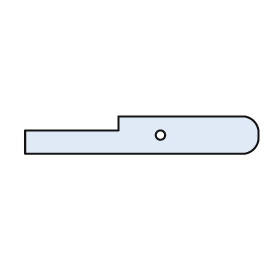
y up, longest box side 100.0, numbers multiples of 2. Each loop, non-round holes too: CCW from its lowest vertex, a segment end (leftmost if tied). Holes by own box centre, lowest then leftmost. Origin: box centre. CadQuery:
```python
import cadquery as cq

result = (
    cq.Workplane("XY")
    .moveTo(-50.0, -8.0)
    .lineTo(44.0, -8.0)
    .threePointArc((48.0, -6.0), (50.0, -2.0))
    .lineTo(50.0, 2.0)
    .threePointArc((48.0, 6.0), (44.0, 8.0))
    .lineTo(-10.0, 8.0)
    .lineTo(-10.0, 2.0)
    .lineTo(-50.0, 2.0)
    .close()
    .moveTo(8.0, 0.0)
    .circle(2.0)
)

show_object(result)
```